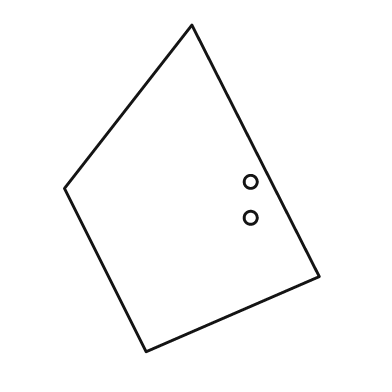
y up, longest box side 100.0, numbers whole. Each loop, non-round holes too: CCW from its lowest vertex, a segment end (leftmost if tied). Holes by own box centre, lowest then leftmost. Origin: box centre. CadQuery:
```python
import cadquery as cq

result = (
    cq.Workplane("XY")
    .moveTo(-14.0, -50.0)
    .lineTo(39.0, -27.0)
    .lineTo(0.0, 50.0)
    .lineTo(-39.0, 0.0)
    .close()
    .moveTo(18.0, -9.0)
    .circle(2.0)
    .moveTo(18.0, 2.0)
    .circle(2.0)
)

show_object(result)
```